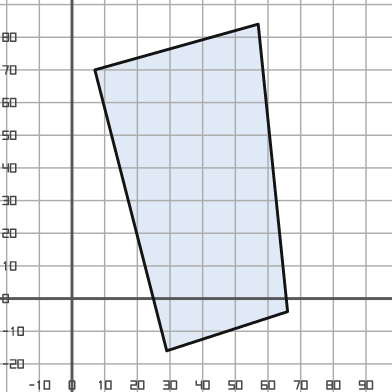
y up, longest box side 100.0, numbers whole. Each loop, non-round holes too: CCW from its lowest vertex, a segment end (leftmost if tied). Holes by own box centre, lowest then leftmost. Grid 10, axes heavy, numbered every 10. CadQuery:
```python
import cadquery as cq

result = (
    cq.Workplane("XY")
    .moveTo(29.0, -16.0)
    .lineTo(66.0, -4.0)
    .lineTo(57.0, 84.0)
    .lineTo(7.0, 70.0)
    .close()
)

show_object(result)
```